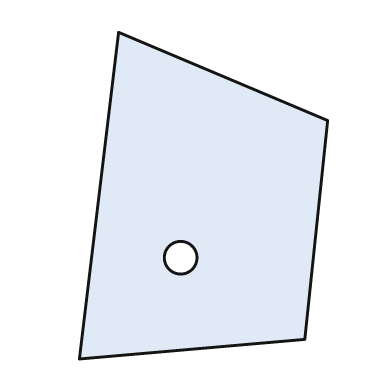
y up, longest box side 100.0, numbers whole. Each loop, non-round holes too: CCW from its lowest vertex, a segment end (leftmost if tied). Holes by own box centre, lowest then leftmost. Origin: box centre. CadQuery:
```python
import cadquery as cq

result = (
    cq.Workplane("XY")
    .moveTo(-38.0, -50.0)
    .lineTo(31.0, -44.0)
    .lineTo(38.0, 23.0)
    .lineTo(-26.0, 50.0)
    .close()
    .moveTo(-7.0, -19.0)
    .circle(5.0)
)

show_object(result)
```